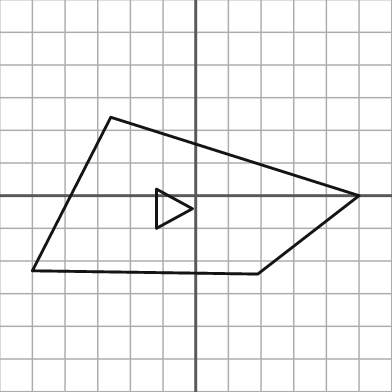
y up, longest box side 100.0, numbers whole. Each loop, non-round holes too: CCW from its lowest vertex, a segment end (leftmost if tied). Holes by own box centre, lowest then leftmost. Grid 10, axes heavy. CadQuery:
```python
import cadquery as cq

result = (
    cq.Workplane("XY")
    .moveTo(19.0, -24.0)
    .lineTo(50.0, 0.0)
    .lineTo(-26.0, 24.0)
    .lineTo(-50.0, -23.0)
    .close()
    .moveTo(-12.0, -10.0)
    .lineTo(-1.0, -4.0)
    .lineTo(-12.0, 2.0)
    .close()
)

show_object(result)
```